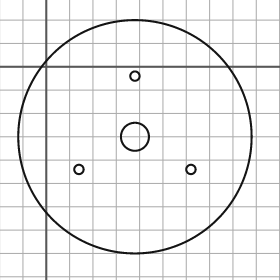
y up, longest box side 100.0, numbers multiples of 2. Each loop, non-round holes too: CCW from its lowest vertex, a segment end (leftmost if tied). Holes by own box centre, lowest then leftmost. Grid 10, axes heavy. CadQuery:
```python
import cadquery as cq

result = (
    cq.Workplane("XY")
    .moveTo(38.0, -30.0)
    .circle(50.0)
    .moveTo(14.0, -44.0)
    .circle(2.0)
    .moveTo(62.0, -44.0)
    .circle(2.0)
    .moveTo(38.0, -30.0)
    .circle(6.0)
    .moveTo(38.0, -4.0)
    .circle(2.0)
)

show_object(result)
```